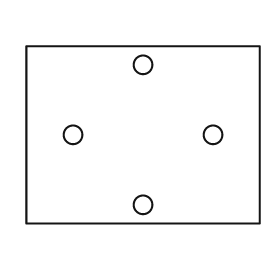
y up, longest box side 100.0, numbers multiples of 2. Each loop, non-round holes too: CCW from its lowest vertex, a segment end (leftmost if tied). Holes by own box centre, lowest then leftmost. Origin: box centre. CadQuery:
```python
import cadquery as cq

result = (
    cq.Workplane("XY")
    .moveTo(-50.0, -38.0)
    .lineTo(50.0, -38.0)
    .lineTo(50.0, 38.0)
    .lineTo(-50.0, 38.0)
    .close()
    .moveTo(0.0, -30.0)
    .circle(4.0)
    .moveTo(-30.0, 0.0)
    .circle(4.0)
    .moveTo(30.0, 0.0)
    .circle(4.0)
    .moveTo(0.0, 30.0)
    .circle(4.0)
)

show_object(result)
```